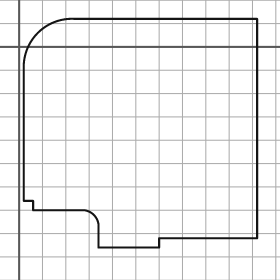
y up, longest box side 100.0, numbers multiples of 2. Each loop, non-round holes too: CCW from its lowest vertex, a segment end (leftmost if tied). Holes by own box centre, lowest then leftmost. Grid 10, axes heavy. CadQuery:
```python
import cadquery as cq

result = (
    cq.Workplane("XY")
    .moveTo(34.0, -86.0)
    .lineTo(60.0, -86.0)
    .lineTo(60.0, -82.0)
    .lineTo(102.0, -82.0)
    .lineTo(102.0, 12.0)
    .lineTo(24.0, 12.0)
    .threePointArc((8.0, 6.0), (2.0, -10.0))
    .lineTo(2.0, -66.0)
    .lineTo(6.0, -66.0)
    .lineTo(6.0, -70.0)
    .lineTo(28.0, -70.0)
    .threePointArc((32.0, -72.0), (34.0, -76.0))
    .close()
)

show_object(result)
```